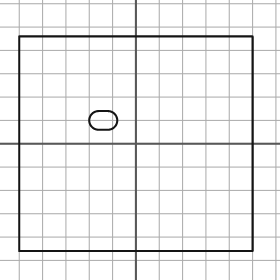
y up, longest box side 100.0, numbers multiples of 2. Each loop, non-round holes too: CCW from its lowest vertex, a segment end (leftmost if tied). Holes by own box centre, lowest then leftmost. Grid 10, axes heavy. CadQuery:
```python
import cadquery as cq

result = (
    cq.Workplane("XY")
    .moveTo(-50.0, -46.0)
    .lineTo(50.0, -46.0)
    .lineTo(50.0, 46.0)
    .lineTo(-50.0, 46.0)
    .close()
    .moveTo(-16.0, 6.0)
    .lineTo(-12.0, 6.0)
    .threePointArc((-8.0, 10.0), (-12.0, 14.0))
    .lineTo(-16.0, 14.0)
    .threePointArc((-20.0, 10.0), (-16.0, 6.0))
    .close()
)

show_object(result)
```